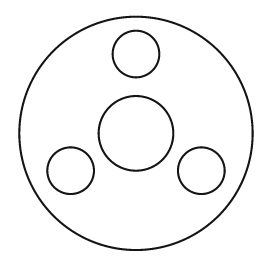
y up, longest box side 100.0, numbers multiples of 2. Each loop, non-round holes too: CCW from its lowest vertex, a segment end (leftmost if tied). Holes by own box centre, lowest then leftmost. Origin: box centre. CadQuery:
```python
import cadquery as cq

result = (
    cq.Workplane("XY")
    .moveTo(0.0, 0.0)
    .circle(50.0)
    .moveTo(-28.0, -16.0)
    .circle(10.0)
    .moveTo(28.0, -16.0)
    .circle(10.0)
    .moveTo(0.0, 0.0)
    .circle(16.0)
    .moveTo(0.0, 34.0)
    .circle(10.0)
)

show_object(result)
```